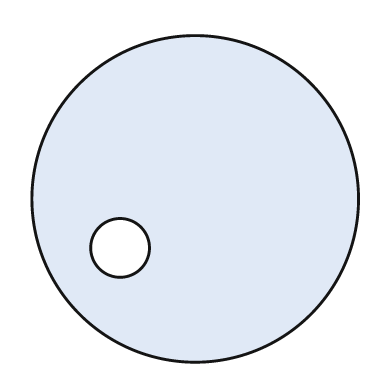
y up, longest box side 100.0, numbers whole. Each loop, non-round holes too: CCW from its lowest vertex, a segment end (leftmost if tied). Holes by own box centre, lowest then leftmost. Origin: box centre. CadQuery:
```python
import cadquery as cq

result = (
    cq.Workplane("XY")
    .moveTo(0.0, 0.0)
    .circle(50.0)
    .moveTo(-23.0, -15.0)
    .circle(9.0)
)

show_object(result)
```